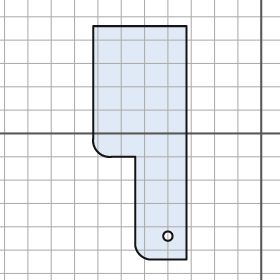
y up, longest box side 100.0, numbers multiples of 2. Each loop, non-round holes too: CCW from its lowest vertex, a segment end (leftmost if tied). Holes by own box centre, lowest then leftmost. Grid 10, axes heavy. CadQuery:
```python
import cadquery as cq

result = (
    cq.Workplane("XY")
    .moveTo(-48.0, -54.0)
    .lineTo(-32.0, -54.0)
    .lineTo(-32.0, 46.0)
    .lineTo(-72.0, 46.0)
    .lineTo(-72.0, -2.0)
    .threePointArc((-70.0, -8.0), (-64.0, -10.0))
    .lineTo(-54.0, -10.0)
    .lineTo(-54.0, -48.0)
    .threePointArc((-52.0, -52.0), (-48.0, -54.0))
    .close()
    .moveTo(-40.0, -44.0)
    .circle(2.0)
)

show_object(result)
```